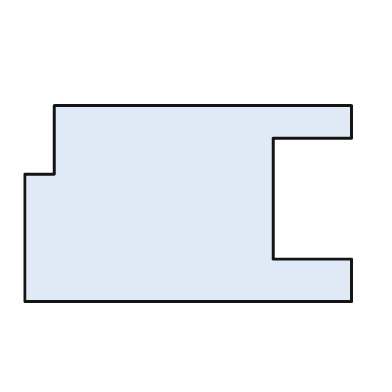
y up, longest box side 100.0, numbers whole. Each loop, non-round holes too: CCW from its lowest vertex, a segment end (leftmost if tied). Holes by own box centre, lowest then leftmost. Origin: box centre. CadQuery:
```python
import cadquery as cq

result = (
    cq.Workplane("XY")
    .moveTo(-50.0, -30.0)
    .lineTo(50.0, -30.0)
    .lineTo(50.0, -17.0)
    .lineTo(26.0, -17.0)
    .lineTo(26.0, 20.0)
    .lineTo(50.0, 20.0)
    .lineTo(50.0, 30.0)
    .lineTo(-41.0, 30.0)
    .lineTo(-41.0, 9.0)
    .lineTo(-50.0, 9.0)
    .close()
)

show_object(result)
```